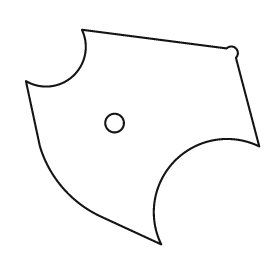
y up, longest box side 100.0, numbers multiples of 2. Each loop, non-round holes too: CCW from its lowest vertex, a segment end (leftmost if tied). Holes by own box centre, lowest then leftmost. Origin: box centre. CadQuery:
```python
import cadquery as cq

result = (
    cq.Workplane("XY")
    .moveTo(8.0, -46.0)
    .threePointArc((14.0, -10.0), (50.0, -4.0))
    .lineTo(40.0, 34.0)
    .threePointArc((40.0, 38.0), (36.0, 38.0))
    .lineTo(-26.0, 46.0)
    .threePointArc((-30.0, 26.0), (-50.0, 24.0))
    .lineTo(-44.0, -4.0)
    .threePointArc((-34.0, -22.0), (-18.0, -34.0))
    .close()
    .moveTo(-12.0, 6.0)
    .circle(4.0)
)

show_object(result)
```